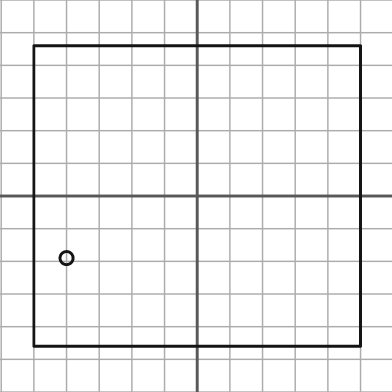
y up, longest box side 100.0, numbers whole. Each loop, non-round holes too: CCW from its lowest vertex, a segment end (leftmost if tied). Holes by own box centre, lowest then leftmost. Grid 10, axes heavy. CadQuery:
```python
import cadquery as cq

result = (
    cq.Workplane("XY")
    .moveTo(-50.0, -46.0)
    .lineTo(50.0, -46.0)
    .lineTo(50.0, 46.0)
    .lineTo(-50.0, 46.0)
    .close()
    .moveTo(-40.0, -19.0)
    .circle(2.0)
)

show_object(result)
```